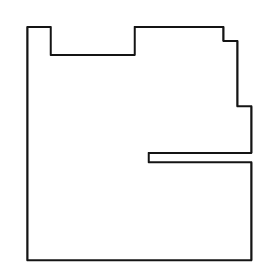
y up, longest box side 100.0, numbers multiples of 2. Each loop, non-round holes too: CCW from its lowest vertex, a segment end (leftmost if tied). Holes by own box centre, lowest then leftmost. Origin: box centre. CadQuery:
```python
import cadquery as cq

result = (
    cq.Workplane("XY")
    .moveTo(-48.0, -50.0)
    .lineTo(48.0, -50.0)
    .lineTo(48.0, -8.0)
    .lineTo(4.0, -8.0)
    .lineTo(4.0, -4.0)
    .lineTo(48.0, -4.0)
    .lineTo(48.0, 16.0)
    .lineTo(42.0, 16.0)
    .lineTo(42.0, 44.0)
    .lineTo(36.0, 44.0)
    .lineTo(36.0, 50.0)
    .lineTo(-2.0, 50.0)
    .lineTo(-2.0, 38.0)
    .lineTo(-38.0, 38.0)
    .lineTo(-38.0, 50.0)
    .lineTo(-48.0, 50.0)
    .close()
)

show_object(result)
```